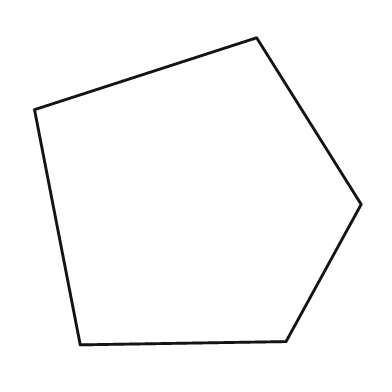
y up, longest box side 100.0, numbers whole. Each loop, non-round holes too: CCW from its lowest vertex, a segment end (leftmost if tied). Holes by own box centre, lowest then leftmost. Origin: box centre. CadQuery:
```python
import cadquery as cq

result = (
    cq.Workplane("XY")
    .moveTo(-36.0, -47.0)
    .lineTo(27.0, -46.0)
    .lineTo(50.0, -4.0)
    .lineTo(18.0, 47.0)
    .lineTo(-50.0, 25.0)
    .close()
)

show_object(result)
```